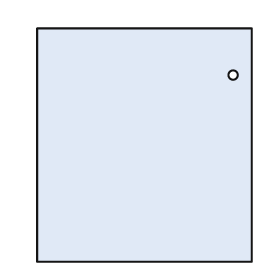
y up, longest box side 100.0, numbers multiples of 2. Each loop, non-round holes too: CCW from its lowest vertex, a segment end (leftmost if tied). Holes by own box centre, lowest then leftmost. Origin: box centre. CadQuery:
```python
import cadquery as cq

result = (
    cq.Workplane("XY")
    .moveTo(-46.0, -50.0)
    .lineTo(46.0, -50.0)
    .lineTo(46.0, 50.0)
    .lineTo(-46.0, 50.0)
    .close()
    .moveTo(38.0, 30.0)
    .circle(2.0)
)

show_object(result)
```